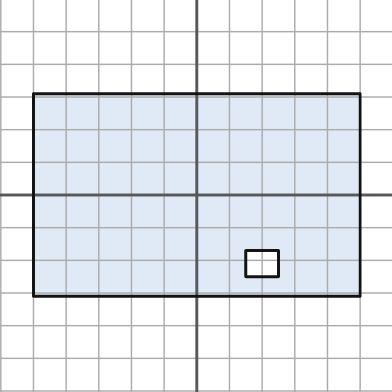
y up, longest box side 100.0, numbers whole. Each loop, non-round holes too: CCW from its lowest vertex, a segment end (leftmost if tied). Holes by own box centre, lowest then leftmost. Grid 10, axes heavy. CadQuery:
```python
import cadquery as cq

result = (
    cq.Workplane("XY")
    .moveTo(-50.0, -31.0)
    .lineTo(50.0, -31.0)
    .lineTo(50.0, 31.0)
    .lineTo(-50.0, 31.0)
    .close()
    .moveTo(15.0, -25.0)
    .lineTo(25.0, -25.0)
    .lineTo(25.0, -17.0)
    .lineTo(15.0, -17.0)
    .close()
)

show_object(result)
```